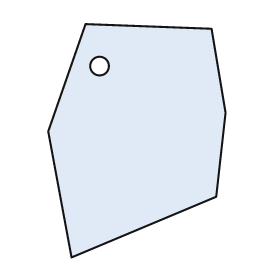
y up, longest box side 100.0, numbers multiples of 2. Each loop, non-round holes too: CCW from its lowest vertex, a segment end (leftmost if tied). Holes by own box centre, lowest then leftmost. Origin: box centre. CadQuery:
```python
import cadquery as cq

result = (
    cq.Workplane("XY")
    .moveTo(-28.0, -50.0)
    .lineTo(34.0, -24.0)
    .lineTo(38.0, 12.0)
    .lineTo(32.0, 48.0)
    .lineTo(-22.0, 50.0)
    .lineTo(-38.0, 4.0)
    .close()
    .moveTo(-16.0, 32.0)
    .circle(4.0)
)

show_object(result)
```